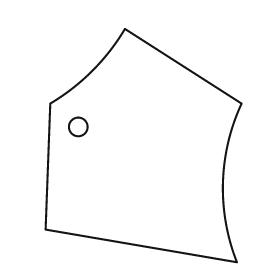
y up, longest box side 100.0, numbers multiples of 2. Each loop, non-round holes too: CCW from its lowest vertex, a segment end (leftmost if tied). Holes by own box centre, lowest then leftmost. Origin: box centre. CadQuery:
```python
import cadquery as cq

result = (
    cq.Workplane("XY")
    .moveTo(40.0, -50.0)
    .threePointArc((34.0, -16.0), (42.0, 18.0))
    .lineTo(-8.0, 50.0)
    .threePointArc((-22.0, 32.0), (-40.0, 18.0))
    .lineTo(-42.0, -36.0)
    .close()
    .moveTo(-28.0, 8.0)
    .circle(4.0)
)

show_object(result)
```